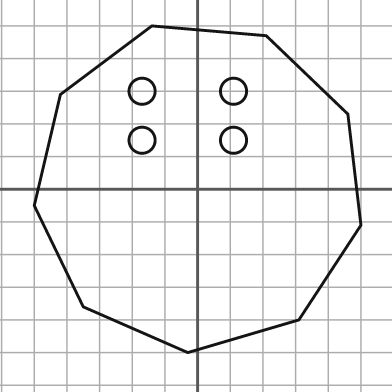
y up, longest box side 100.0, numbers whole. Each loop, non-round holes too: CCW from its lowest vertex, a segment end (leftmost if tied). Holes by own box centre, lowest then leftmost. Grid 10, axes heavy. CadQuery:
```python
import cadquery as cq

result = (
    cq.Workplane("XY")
    .moveTo(-3.0, -50.0)
    .lineTo(31.0, -40.0)
    .lineTo(50.0, -11.0)
    .lineTo(46.0, 23.0)
    .lineTo(21.0, 47.0)
    .lineTo(-14.0, 50.0)
    .lineTo(-42.0, 29.0)
    .lineTo(-50.0, -5.0)
    .lineTo(-35.0, -36.0)
    .close()
    .moveTo(-17.0, 15.0)
    .circle(4.0)
    .moveTo(11.0, 15.0)
    .circle(4.0)
    .moveTo(-17.0, 30.0)
    .circle(4.0)
    .moveTo(11.0, 30.0)
    .circle(4.0)
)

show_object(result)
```